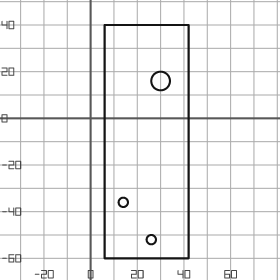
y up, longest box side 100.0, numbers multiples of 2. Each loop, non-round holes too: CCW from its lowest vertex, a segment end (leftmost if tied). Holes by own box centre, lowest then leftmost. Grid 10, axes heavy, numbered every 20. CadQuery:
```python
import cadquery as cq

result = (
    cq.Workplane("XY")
    .moveTo(6.0, -60.0)
    .lineTo(42.0, -60.0)
    .lineTo(42.0, 40.0)
    .lineTo(6.0, 40.0)
    .close()
    .moveTo(26.0, -52.0)
    .circle(2.0)
    .moveTo(14.0, -36.0)
    .circle(2.0)
    .moveTo(30.0, 16.0)
    .circle(4.0)
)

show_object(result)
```